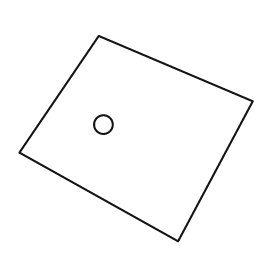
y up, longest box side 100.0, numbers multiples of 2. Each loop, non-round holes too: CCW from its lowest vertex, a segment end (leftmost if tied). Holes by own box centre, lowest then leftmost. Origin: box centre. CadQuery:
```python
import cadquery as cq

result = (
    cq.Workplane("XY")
    .moveTo(18.0, -44.0)
    .lineTo(50.0, 16.0)
    .lineTo(-16.0, 44.0)
    .lineTo(-50.0, -6.0)
    .close()
    .moveTo(-14.0, 6.0)
    .circle(4.0)
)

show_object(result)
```